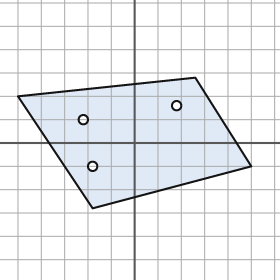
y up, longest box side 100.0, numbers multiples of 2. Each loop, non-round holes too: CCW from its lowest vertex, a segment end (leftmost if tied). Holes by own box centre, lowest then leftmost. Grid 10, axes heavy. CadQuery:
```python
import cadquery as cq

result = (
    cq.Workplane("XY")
    .moveTo(-18.0, -28.0)
    .lineTo(50.0, -10.0)
    .lineTo(26.0, 28.0)
    .lineTo(-50.0, 20.0)
    .close()
    .moveTo(-18.0, -10.0)
    .circle(2.0)
    .moveTo(-22.0, 10.0)
    .circle(2.0)
    .moveTo(18.0, 16.0)
    .circle(2.0)
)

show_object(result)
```